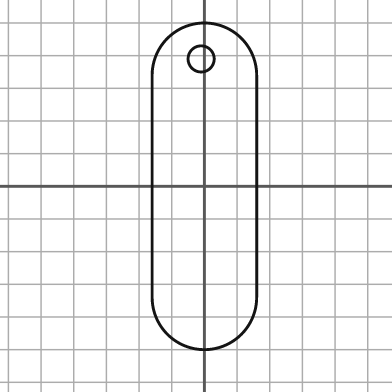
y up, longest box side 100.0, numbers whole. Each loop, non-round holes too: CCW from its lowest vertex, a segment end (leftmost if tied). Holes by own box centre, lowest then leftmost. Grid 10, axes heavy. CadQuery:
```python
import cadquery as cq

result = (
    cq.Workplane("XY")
    .moveTo(-16.0, -34.0)
    .threePointArc((0.0, -50.0), (16.0, -34.0))
    .lineTo(16.0, 34.0)
    .threePointArc((0.0, 50.0), (-16.0, 34.0))
    .close()
    .moveTo(-1.0, 39.0)
    .circle(4.0)
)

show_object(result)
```